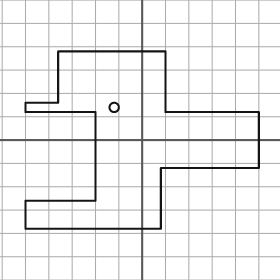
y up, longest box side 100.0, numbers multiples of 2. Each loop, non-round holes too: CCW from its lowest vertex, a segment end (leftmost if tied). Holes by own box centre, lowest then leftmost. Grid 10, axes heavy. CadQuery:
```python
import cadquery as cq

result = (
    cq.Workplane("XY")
    .moveTo(-50.0, -38.0)
    .lineTo(8.0, -38.0)
    .lineTo(8.0, -12.0)
    .lineTo(50.0, -12.0)
    .lineTo(50.0, 12.0)
    .lineTo(10.0, 12.0)
    .lineTo(10.0, 38.0)
    .lineTo(-36.0, 38.0)
    .lineTo(-36.0, 16.0)
    .lineTo(-50.0, 16.0)
    .lineTo(-50.0, 12.0)
    .lineTo(-20.0, 12.0)
    .lineTo(-20.0, -26.0)
    .lineTo(-50.0, -26.0)
    .close()
    .moveTo(-12.0, 14.0)
    .circle(2.0)
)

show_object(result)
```